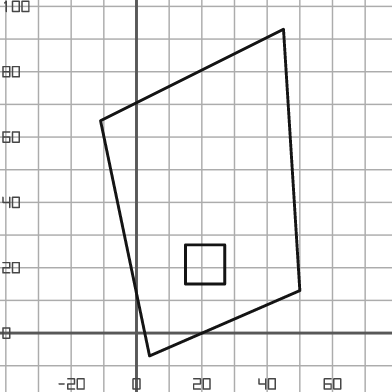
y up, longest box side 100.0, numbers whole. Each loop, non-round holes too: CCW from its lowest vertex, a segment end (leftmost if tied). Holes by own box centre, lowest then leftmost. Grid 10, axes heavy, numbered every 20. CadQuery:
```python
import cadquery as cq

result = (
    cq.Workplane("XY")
    .moveTo(4.0, -7.0)
    .lineTo(50.0, 13.0)
    .lineTo(45.0, 93.0)
    .lineTo(-11.0, 65.0)
    .close()
    .moveTo(15.0, 15.0)
    .lineTo(27.0, 15.0)
    .lineTo(27.0, 27.0)
    .lineTo(15.0, 27.0)
    .close()
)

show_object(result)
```